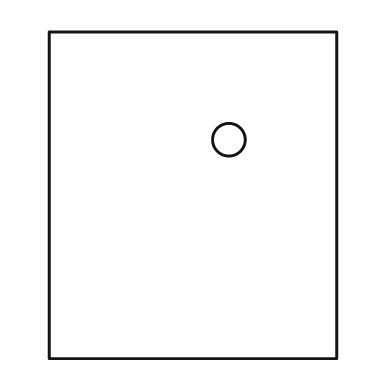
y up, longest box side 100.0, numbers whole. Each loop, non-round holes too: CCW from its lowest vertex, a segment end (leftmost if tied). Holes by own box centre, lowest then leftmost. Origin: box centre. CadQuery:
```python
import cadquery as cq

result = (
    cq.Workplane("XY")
    .moveTo(-44.0, -50.0)
    .lineTo(44.0, -50.0)
    .lineTo(44.0, 50.0)
    .lineTo(-44.0, 50.0)
    .close()
    .moveTo(11.0, 17.0)
    .circle(5.0)
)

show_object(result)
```